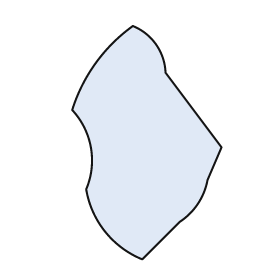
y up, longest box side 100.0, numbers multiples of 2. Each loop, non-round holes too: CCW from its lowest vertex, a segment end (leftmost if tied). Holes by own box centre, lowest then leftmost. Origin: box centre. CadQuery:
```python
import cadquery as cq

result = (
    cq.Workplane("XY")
    .moveTo(-2.0, -50.0)
    .lineTo(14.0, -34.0)
    .threePointArc((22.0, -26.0), (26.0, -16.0))
    .lineTo(32.0, -2.0)
    .lineTo(8.0, 30.0)
    .threePointArc((4.0, 42.0), (-6.0, 50.0))
    .threePointArc((-22.0, 34.0), (-32.0, 14.0))
    .threePointArc((-24.0, -2.0), (-26.0, -20.0))
    .threePointArc((-18.0, -38.0), (-2.0, -50.0))
    .close()
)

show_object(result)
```